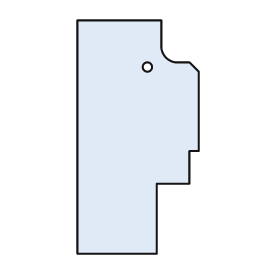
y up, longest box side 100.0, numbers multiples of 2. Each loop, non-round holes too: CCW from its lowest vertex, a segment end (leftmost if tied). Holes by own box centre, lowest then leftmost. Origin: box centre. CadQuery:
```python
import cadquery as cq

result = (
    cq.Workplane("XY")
    .moveTo(-26.0, -50.0)
    .lineTo(8.0, -50.0)
    .lineTo(8.0, -20.0)
    .lineTo(22.0, -20.0)
    .lineTo(22.0, -6.0)
    .lineTo(26.0, -6.0)
    .lineTo(26.0, 28.0)
    .lineTo(22.0, 32.0)
    .lineTo(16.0, 32.0)
    .threePointArc((12.0, 34.0), (10.0, 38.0))
    .lineTo(10.0, 50.0)
    .lineTo(-26.0, 50.0)
    .close()
    .moveTo(4.0, 30.0)
    .circle(2.0)
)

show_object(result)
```